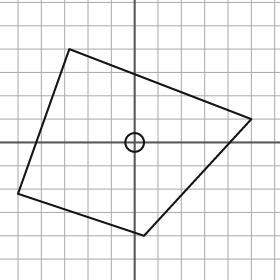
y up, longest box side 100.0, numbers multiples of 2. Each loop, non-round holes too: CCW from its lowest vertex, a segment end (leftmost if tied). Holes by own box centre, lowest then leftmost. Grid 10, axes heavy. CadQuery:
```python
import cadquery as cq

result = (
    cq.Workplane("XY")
    .moveTo(4.0, -40.0)
    .lineTo(50.0, 10.0)
    .lineTo(-28.0, 40.0)
    .lineTo(-50.0, -22.0)
    .close()
    .moveTo(0.0, 0.0)
    .circle(4.0)
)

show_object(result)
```